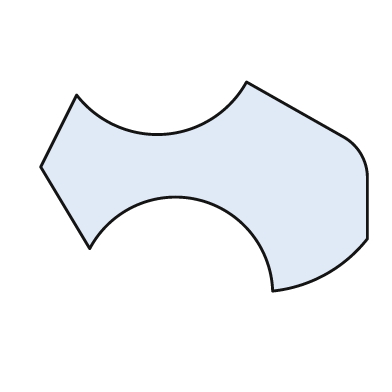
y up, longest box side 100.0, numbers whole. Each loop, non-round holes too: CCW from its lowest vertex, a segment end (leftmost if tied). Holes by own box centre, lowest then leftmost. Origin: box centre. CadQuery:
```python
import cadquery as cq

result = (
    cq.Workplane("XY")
    .moveTo(21.0, -32.0)
    .threePointArc((37.0, -27.0), (50.0, -16.0))
    .lineTo(50.0, 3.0)
    .threePointArc((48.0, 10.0), (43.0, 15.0))
    .lineTo(13.0, 32.0)
    .threePointArc((-12.0, 16.0), (-39.0, 28.0))
    .lineTo(-50.0, 6.0)
    .lineTo(-35.0, -19.0)
    .threePointArc((-2.0, -4.0), (21.0, -32.0))
    .close()
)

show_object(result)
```